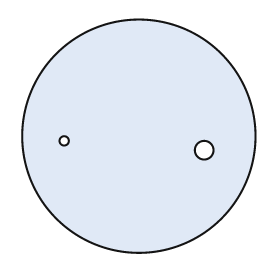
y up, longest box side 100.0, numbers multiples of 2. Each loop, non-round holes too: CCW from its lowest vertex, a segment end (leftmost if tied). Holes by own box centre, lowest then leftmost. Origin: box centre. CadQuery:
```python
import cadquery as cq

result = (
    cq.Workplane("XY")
    .moveTo(0.0, 0.0)
    .circle(50.0)
    .moveTo(28.0, -6.0)
    .circle(4.0)
    .moveTo(-32.0, -2.0)
    .circle(2.0)
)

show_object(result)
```